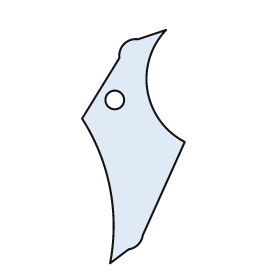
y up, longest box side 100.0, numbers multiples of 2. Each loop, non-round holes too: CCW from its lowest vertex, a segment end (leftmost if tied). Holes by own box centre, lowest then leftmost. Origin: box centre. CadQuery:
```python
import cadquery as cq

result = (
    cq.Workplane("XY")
    .moveTo(-10.0, -50.0)
    .lineTo(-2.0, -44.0)
    .threePointArc((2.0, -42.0), (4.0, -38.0))
    .lineTo(22.0, 2.0)
    .threePointArc((6.0, 24.0), (14.0, 50.0))
    .lineTo(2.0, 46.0)
    .threePointArc((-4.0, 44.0), (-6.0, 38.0))
    .lineTo(-22.0, 12.0)
    .threePointArc((-10.0, -18.0), (-10.0, -50.0))
    .close()
    .moveTo(-8.0, 20.0)
    .circle(4.0)
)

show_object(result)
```